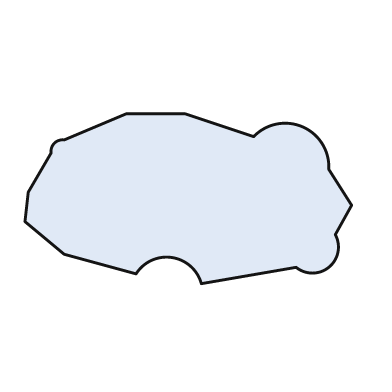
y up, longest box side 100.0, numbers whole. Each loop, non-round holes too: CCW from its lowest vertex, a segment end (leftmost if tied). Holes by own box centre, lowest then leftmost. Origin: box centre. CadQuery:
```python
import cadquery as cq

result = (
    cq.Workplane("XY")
    .moveTo(4.0, -26.0)
    .lineTo(33.0, -21.0)
    .threePointArc((43.0, -21.0), (45.0, -11.0))
    .lineTo(50.0, -2.0)
    .lineTo(43.0, 9.0)
    .threePointArc((35.0, 22.0), (20.0, 19.0))
    .lineTo(-1.0, 26.0)
    .lineTo(-19.0, 26.0)
    .lineTo(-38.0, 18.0)
    .threePointArc((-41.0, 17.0), (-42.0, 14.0))
    .lineTo(-49.0, 2.0)
    .lineTo(-50.0, -7.0)
    .lineTo(-38.0, -17.0)
    .lineTo(-16.0, -23.0)
    .threePointArc((-5.0, -18.0), (4.0, -26.0))
    .close()
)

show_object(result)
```